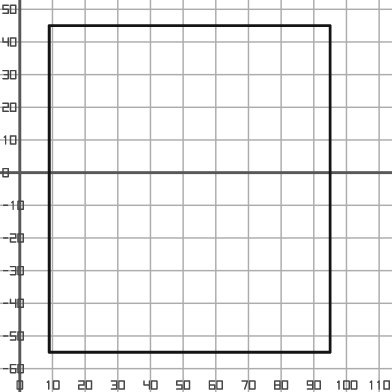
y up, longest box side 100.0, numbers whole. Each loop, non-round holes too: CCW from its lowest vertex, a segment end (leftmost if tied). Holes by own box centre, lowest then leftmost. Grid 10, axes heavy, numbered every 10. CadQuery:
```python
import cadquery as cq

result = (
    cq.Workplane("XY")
    .moveTo(9.0, -55.0)
    .lineTo(95.0, -55.0)
    .lineTo(95.0, 45.0)
    .lineTo(9.0, 45.0)
    .close()
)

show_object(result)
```